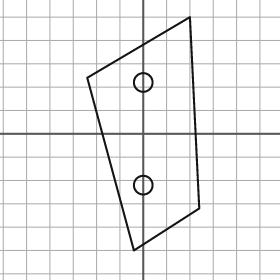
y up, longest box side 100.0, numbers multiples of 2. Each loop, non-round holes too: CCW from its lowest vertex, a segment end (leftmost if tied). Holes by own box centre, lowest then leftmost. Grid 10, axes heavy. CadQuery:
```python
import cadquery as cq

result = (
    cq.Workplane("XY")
    .moveTo(-4.0, -50.0)
    .lineTo(24.0, -32.0)
    .lineTo(20.0, 50.0)
    .lineTo(-24.0, 24.0)
    .close()
    .moveTo(0.0, -22.0)
    .circle(4.0)
    .moveTo(0.0, 22.0)
    .circle(4.0)
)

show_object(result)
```